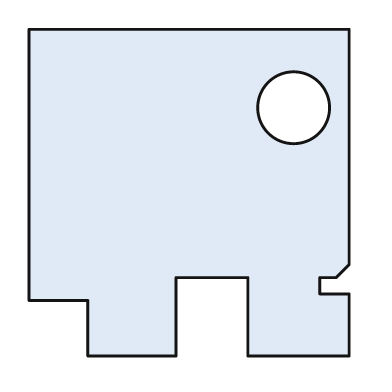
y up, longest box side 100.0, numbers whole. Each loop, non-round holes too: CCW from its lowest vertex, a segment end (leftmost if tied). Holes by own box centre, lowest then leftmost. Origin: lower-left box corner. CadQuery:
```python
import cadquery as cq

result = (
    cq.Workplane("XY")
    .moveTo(18.0, 0.0)
    .lineTo(45.0, 0.0)
    .lineTo(45.0, 24.0)
    .lineTo(67.0, 24.0)
    .lineTo(67.0, 0.0)
    .lineTo(98.0, 0.0)
    .lineTo(98.0, 19.0)
    .lineTo(89.0, 19.0)
    .lineTo(89.0, 24.0)
    .lineTo(94.0, 24.0)
    .lineTo(98.0, 28.0)
    .lineTo(98.0, 100.0)
    .lineTo(0.0, 100.0)
    .lineTo(0.0, 17.0)
    .lineTo(18.0, 17.0)
    .close()
    .moveTo(81.0, 76.0)
    .circle(11.0)
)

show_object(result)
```